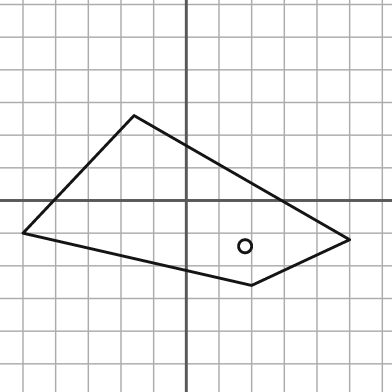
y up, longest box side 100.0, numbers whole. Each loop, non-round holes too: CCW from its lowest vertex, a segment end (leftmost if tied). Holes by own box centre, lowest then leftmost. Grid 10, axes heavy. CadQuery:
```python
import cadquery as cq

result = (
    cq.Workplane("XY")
    .moveTo(20.0, -26.0)
    .lineTo(50.0, -12.0)
    .lineTo(-16.0, 26.0)
    .lineTo(-50.0, -10.0)
    .close()
    .moveTo(18.0, -14.0)
    .circle(2.0)
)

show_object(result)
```